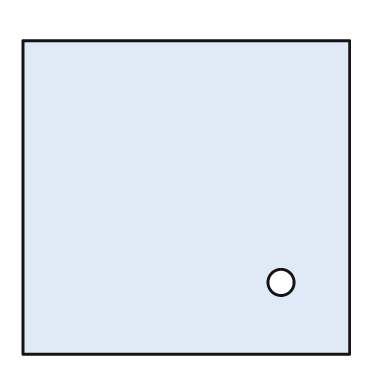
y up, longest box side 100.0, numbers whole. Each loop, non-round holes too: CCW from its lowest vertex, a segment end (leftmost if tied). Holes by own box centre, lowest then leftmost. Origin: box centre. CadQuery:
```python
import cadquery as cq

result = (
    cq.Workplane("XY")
    .moveTo(-50.0, -48.0)
    .lineTo(50.0, -48.0)
    .lineTo(50.0, 48.0)
    .lineTo(-50.0, 48.0)
    .close()
    .moveTo(29.0, -26.0)
    .circle(4.0)
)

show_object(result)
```